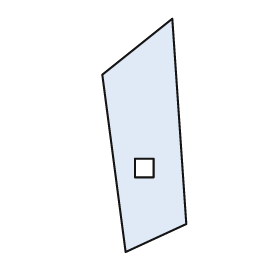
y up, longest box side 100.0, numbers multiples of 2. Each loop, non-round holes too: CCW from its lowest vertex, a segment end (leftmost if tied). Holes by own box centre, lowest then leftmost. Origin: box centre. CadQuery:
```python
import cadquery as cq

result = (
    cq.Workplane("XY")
    .moveTo(-8.0, -50.0)
    .lineTo(18.0, -38.0)
    .lineTo(12.0, 50.0)
    .lineTo(-18.0, 26.0)
    .close()
    .moveTo(-4.0, -18.0)
    .lineTo(4.0, -18.0)
    .lineTo(4.0, -10.0)
    .lineTo(-4.0, -10.0)
    .close()
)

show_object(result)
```